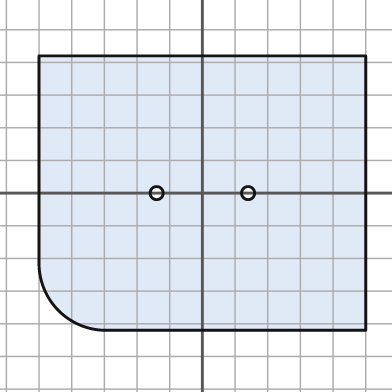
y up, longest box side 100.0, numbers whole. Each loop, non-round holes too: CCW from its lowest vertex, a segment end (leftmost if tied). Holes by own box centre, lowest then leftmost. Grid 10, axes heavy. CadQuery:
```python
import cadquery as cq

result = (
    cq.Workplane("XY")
    .moveTo(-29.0, -42.0)
    .lineTo(50.0, -42.0)
    .lineTo(50.0, 42.0)
    .lineTo(-50.0, 42.0)
    .lineTo(-50.0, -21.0)
    .threePointArc((-44.0, -36.0), (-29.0, -42.0))
    .close()
    .moveTo(-14.0, 0.0)
    .circle(2.0)
    .moveTo(14.0, 0.0)
    .circle(2.0)
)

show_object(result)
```